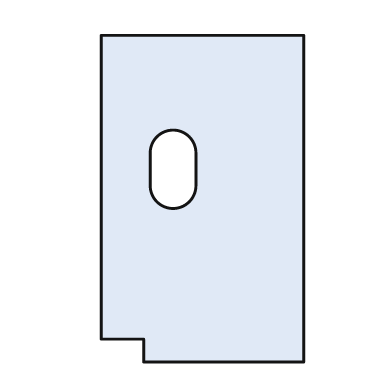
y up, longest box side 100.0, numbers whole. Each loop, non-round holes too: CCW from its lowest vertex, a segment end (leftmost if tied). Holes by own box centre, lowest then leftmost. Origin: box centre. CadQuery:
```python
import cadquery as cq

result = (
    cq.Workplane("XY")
    .moveTo(-18.0, -50.0)
    .lineTo(31.0, -50.0)
    .lineTo(31.0, 50.0)
    .lineTo(-31.0, 50.0)
    .lineTo(-31.0, -43.0)
    .lineTo(-18.0, -43.0)
    .close()
    .moveTo(-16.0, 4.0)
    .threePointArc((-9.0, -3.0), (-2.0, 4.0))
    .lineTo(-2.0, 14.0)
    .threePointArc((-9.0, 21.0), (-16.0, 14.0))
    .close()
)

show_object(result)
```